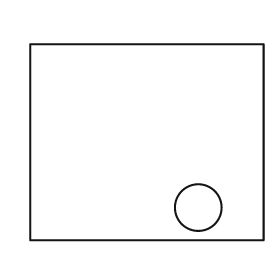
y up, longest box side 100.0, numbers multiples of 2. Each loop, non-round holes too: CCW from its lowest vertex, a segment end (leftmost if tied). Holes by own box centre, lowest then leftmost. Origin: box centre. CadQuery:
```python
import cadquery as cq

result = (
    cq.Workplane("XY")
    .moveTo(-50.0, -42.0)
    .lineTo(50.0, -42.0)
    .lineTo(50.0, 42.0)
    .lineTo(-50.0, 42.0)
    .close()
    .moveTo(22.0, -28.0)
    .circle(10.0)
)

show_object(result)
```